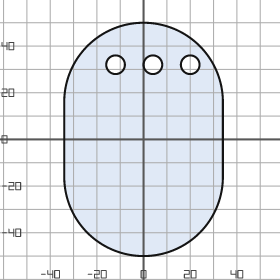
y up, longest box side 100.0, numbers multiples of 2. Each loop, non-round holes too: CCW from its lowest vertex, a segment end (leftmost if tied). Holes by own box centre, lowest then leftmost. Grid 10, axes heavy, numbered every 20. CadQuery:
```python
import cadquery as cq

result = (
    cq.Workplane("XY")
    .moveTo(-34.0, -16.0)
    .threePointArc((0.0, -50.0), (34.0, -16.0))
    .lineTo(34.0, 16.0)
    .threePointArc((0.0, 50.0), (-34.0, 16.0))
    .close()
    .moveTo(-12.0, 32.0)
    .circle(4.0)
    .moveTo(4.0, 32.0)
    .circle(4.0)
    .moveTo(20.0, 32.0)
    .circle(4.0)
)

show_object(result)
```